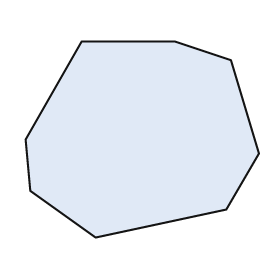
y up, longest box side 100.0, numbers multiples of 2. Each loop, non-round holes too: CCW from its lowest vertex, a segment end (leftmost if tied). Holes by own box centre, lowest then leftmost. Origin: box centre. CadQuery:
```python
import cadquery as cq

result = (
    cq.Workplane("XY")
    .moveTo(-20.0, -42.0)
    .lineTo(36.0, -30.0)
    .lineTo(50.0, -6.0)
    .lineTo(38.0, 34.0)
    .lineTo(14.0, 42.0)
    .lineTo(-26.0, 42.0)
    .lineTo(-50.0, 0.0)
    .lineTo(-48.0, -22.0)
    .close()
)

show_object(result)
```